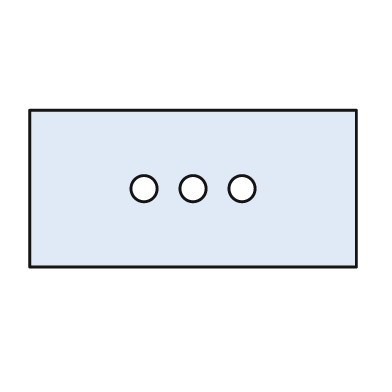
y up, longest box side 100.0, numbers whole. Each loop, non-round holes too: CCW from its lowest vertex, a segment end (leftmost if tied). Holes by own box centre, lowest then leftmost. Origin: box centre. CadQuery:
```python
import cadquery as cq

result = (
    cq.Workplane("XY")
    .moveTo(-50.0, -24.0)
    .lineTo(50.0, -24.0)
    .lineTo(50.0, 24.0)
    .lineTo(-50.0, 24.0)
    .close()
    .moveTo(-15.0, 0.0)
    .circle(4.0)
    .moveTo(0.0, 0.0)
    .circle(4.0)
    .moveTo(15.0, 0.0)
    .circle(4.0)
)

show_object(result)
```